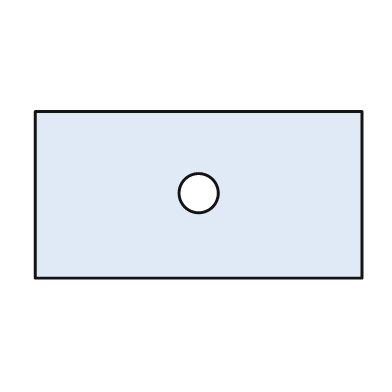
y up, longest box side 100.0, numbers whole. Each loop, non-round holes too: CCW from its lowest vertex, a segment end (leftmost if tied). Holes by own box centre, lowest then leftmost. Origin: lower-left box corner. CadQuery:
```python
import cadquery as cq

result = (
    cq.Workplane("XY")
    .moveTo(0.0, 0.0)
    .lineTo(100.0, 0.0)
    .lineTo(100.0, 51.0)
    .lineTo(0.0, 51.0)
    .close()
    .moveTo(50.0, 26.0)
    .circle(6.0)
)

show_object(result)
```